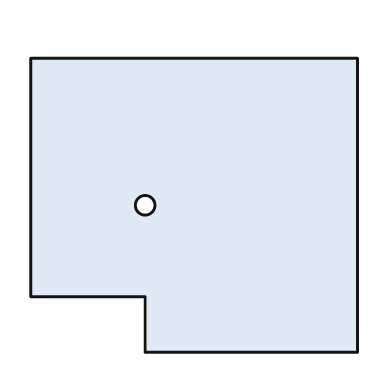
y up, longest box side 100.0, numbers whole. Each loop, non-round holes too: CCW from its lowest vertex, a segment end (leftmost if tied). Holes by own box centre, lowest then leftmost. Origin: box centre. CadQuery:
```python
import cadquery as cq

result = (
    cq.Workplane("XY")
    .moveTo(-15.0, -45.0)
    .lineTo(50.0, -45.0)
    .lineTo(50.0, 45.0)
    .lineTo(-50.0, 45.0)
    .lineTo(-50.0, -28.0)
    .lineTo(-15.0, -28.0)
    .close()
    .moveTo(-15.0, 0.0)
    .circle(3.0)
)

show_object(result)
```